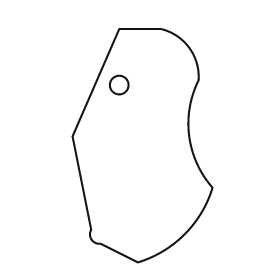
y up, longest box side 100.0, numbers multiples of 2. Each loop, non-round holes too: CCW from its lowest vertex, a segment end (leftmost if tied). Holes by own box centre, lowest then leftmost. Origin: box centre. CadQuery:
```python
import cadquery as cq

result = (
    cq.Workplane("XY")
    .moveTo(-2.0, -50.0)
    .threePointArc((18.0, -38.0), (30.0, -18.0))
    .threePointArc((20.0, 4.0), (24.0, 28.0))
    .threePointArc((20.0, 42.0), (8.0, 50.0))
    .lineTo(-10.0, 50.0)
    .lineTo(-30.0, 4.0)
    .lineTo(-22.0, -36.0)
    .threePointArc((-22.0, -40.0), (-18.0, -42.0))
    .close()
    .moveTo(-10.0, 26.0)
    .circle(4.0)
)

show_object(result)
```